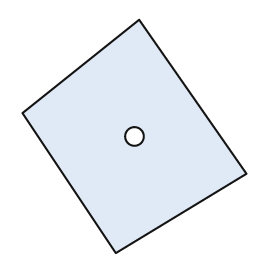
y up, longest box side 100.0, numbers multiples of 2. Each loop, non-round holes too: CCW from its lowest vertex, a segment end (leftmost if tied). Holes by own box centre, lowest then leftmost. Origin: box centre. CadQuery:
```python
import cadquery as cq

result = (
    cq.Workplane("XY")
    .moveTo(-8.0, -50.0)
    .lineTo(48.0, -16.0)
    .lineTo(2.0, 50.0)
    .lineTo(-48.0, 10.0)
    .close()
    .moveTo(0.0, 0.0)
    .circle(4.0)
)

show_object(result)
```